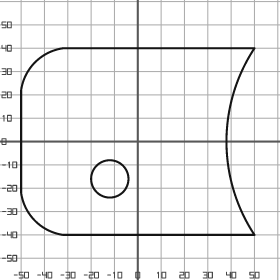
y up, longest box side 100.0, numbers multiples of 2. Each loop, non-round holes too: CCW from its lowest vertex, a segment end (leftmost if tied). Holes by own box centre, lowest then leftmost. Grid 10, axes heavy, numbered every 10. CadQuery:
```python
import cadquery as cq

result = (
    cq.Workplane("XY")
    .moveTo(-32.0, -40.0)
    .lineTo(50.0, -40.0)
    .threePointArc((38.0, 0.0), (50.0, 40.0))
    .lineTo(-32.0, 40.0)
    .threePointArc((-44.0, 34.0), (-50.0, 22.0))
    .lineTo(-50.0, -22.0)
    .threePointArc((-44.0, -34.0), (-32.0, -40.0))
    .close()
    .moveTo(-12.0, -16.0)
    .circle(8.0)
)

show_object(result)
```